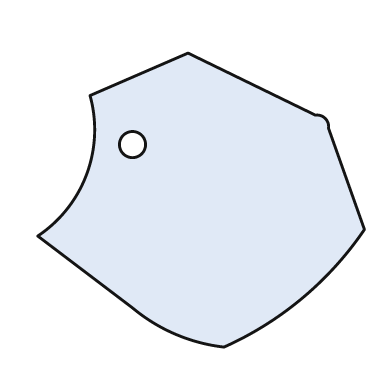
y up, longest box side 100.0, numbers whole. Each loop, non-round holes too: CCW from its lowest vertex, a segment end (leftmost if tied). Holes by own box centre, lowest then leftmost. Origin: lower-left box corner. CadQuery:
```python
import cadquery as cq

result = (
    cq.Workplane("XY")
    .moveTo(57.0, 0.0)
    .threePointArc((81.0, 15.0), (100.0, 36.0))
    .lineTo(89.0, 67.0)
    .threePointArc((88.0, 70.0), (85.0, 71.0))
    .lineTo(46.0, 90.0)
    .lineTo(16.0, 77.0)
    .threePointArc((15.0, 53.0), (0.0, 34.0))
    .lineTo(29.0, 12.0)
    .threePointArc((42.0, 4.0), (57.0, 0.0))
    .close()
    .moveTo(29.0, 62.0)
    .circle(4.0)
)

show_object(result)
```